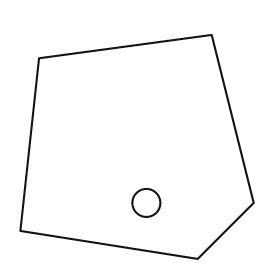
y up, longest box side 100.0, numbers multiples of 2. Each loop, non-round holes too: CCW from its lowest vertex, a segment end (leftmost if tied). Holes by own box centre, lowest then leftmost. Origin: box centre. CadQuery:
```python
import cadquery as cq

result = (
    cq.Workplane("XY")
    .moveTo(26.0, -48.0)
    .lineTo(50.0, -24.0)
    .lineTo(32.0, 48.0)
    .lineTo(-42.0, 38.0)
    .lineTo(-50.0, -36.0)
    .close()
    .moveTo(4.0, -24.0)
    .circle(6.0)
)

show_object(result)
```